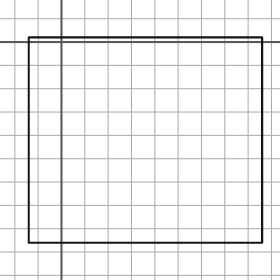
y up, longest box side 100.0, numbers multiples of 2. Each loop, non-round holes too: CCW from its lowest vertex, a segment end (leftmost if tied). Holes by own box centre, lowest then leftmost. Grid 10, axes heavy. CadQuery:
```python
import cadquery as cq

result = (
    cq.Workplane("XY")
    .moveTo(-14.0, -86.0)
    .lineTo(86.0, -86.0)
    .lineTo(86.0, 2.0)
    .lineTo(-14.0, 2.0)
    .close()
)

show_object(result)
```